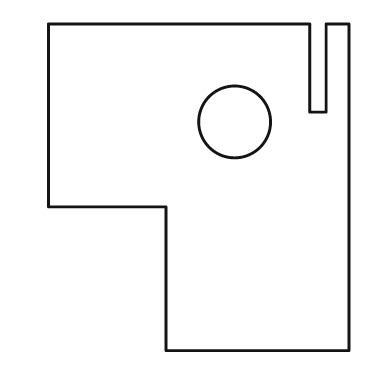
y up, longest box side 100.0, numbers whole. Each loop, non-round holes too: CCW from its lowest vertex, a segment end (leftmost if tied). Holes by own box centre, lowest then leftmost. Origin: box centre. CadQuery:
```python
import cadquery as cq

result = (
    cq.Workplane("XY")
    .moveTo(-10.0, -50.0)
    .lineTo(46.0, -50.0)
    .lineTo(46.0, 50.0)
    .lineTo(39.0, 50.0)
    .lineTo(39.0, 23.0)
    .lineTo(34.0, 23.0)
    .lineTo(34.0, 50.0)
    .lineTo(-46.0, 50.0)
    .lineTo(-46.0, -6.0)
    .lineTo(-10.0, -6.0)
    .close()
    .moveTo(11.0, 20.0)
    .circle(11.0)
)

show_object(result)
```